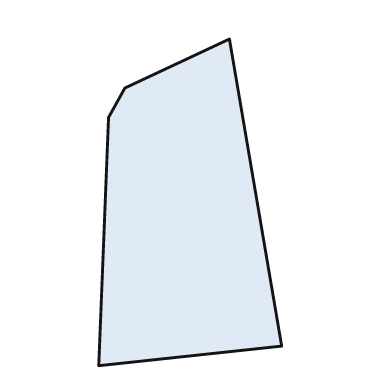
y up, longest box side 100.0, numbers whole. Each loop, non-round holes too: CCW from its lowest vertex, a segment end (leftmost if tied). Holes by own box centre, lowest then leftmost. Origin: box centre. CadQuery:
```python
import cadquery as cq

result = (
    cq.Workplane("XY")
    .moveTo(-28.0, -50.0)
    .lineTo(28.0, -44.0)
    .lineTo(12.0, 50.0)
    .lineTo(-20.0, 35.0)
    .lineTo(-25.0, 26.0)
    .close()
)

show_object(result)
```